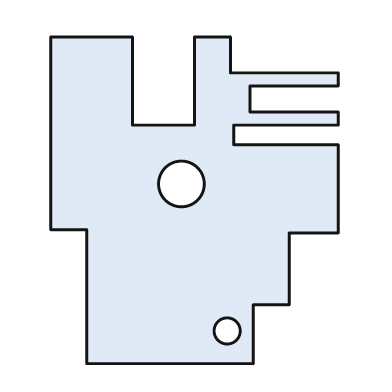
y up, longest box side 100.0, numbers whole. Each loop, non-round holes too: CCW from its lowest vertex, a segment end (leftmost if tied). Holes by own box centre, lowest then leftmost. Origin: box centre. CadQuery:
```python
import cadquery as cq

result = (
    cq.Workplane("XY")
    .moveTo(-33.0, -50.0)
    .lineTo(18.0, -50.0)
    .lineTo(18.0, -32.0)
    .lineTo(29.0, -32.0)
    .lineTo(29.0, -10.0)
    .lineTo(44.0, -10.0)
    .lineTo(44.0, 17.0)
    .lineTo(12.0, 17.0)
    .lineTo(12.0, 23.0)
    .lineTo(44.0, 23.0)
    .lineTo(44.0, 27.0)
    .lineTo(17.0, 27.0)
    .lineTo(17.0, 35.0)
    .lineTo(44.0, 35.0)
    .lineTo(44.0, 39.0)
    .lineTo(11.0, 39.0)
    .lineTo(11.0, 50.0)
    .lineTo(0.0, 50.0)
    .lineTo(0.0, 23.0)
    .lineTo(-19.0, 23.0)
    .lineTo(-19.0, 50.0)
    .lineTo(-44.0, 50.0)
    .lineTo(-44.0, -9.0)
    .lineTo(-33.0, -9.0)
    .close()
    .moveTo(10.0, -40.0)
    .circle(4.0)
    .moveTo(-4.0, 5.0)
    .circle(7.0)
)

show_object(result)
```